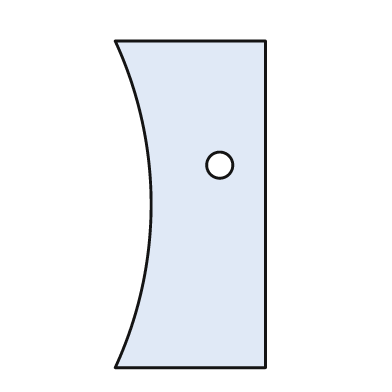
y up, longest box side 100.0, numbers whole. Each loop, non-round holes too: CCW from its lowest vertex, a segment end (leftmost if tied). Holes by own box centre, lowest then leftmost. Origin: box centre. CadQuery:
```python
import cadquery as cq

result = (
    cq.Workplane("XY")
    .moveTo(-23.0, -50.0)
    .lineTo(23.0, -50.0)
    .lineTo(23.0, 50.0)
    .lineTo(-23.0, 50.0)
    .threePointArc((-12.0, 0.0), (-23.0, -50.0))
    .close()
    .moveTo(9.0, 12.0)
    .circle(4.0)
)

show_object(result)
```